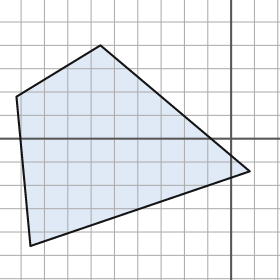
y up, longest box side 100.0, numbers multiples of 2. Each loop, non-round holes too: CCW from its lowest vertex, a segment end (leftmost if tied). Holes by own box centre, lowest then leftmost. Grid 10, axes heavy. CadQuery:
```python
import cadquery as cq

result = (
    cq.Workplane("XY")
    .moveTo(-86.0, -46.0)
    .lineTo(8.0, -14.0)
    .lineTo(-56.0, 40.0)
    .lineTo(-92.0, 18.0)
    .close()
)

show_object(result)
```